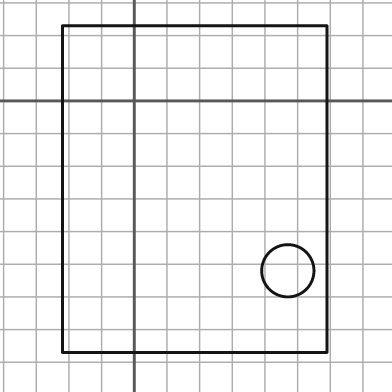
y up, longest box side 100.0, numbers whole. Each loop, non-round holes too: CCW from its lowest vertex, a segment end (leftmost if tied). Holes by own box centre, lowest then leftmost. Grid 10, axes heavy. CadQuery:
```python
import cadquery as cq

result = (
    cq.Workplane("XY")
    .moveTo(-22.0, -77.0)
    .lineTo(59.0, -77.0)
    .lineTo(59.0, 23.0)
    .lineTo(-22.0, 23.0)
    .close()
    .moveTo(47.0, -52.0)
    .circle(8.0)
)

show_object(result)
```